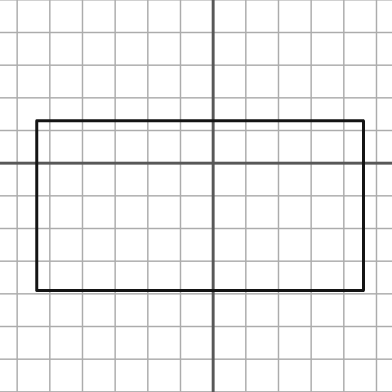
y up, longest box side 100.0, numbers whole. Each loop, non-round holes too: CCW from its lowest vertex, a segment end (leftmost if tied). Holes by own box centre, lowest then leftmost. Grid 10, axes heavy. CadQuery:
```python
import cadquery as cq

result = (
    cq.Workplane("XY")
    .moveTo(-54.0, -39.0)
    .lineTo(46.0, -39.0)
    .lineTo(46.0, 13.0)
    .lineTo(-54.0, 13.0)
    .close()
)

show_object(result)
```